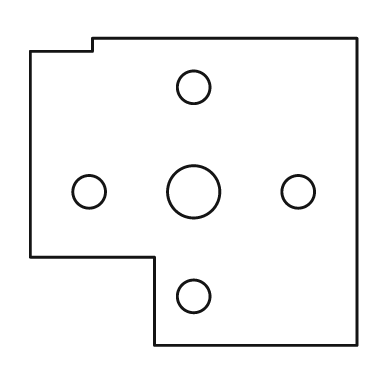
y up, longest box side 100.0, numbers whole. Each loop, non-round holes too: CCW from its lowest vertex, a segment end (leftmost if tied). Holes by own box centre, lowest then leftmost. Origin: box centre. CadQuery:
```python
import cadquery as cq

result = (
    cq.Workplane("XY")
    .moveTo(-12.0, -47.0)
    .lineTo(50.0, -47.0)
    .lineTo(50.0, 47.0)
    .lineTo(-31.0, 47.0)
    .lineTo(-31.0, 43.0)
    .lineTo(-50.0, 43.0)
    .lineTo(-50.0, -20.0)
    .lineTo(-12.0, -20.0)
    .close()
    .moveTo(0.0, -32.0)
    .circle(5.0)
    .moveTo(-32.0, 0.0)
    .circle(5.0)
    .moveTo(0.0, 0.0)
    .circle(8.0)
    .moveTo(32.0, 0.0)
    .circle(5.0)
    .moveTo(0.0, 32.0)
    .circle(5.0)
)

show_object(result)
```